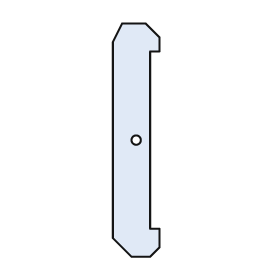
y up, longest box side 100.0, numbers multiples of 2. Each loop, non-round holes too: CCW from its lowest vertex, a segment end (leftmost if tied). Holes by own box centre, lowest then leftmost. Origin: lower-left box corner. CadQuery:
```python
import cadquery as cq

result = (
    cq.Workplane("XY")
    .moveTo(8.0, 0.0)
    .lineTo(16.0, 0.0)
    .lineTo(20.0, 4.0)
    .lineTo(20.0, 12.0)
    .lineTo(16.0, 12.0)
    .lineTo(16.0, 88.0)
    .lineTo(20.0, 88.0)
    .lineTo(20.0, 94.0)
    .lineTo(14.0, 100.0)
    .lineTo(4.0, 100.0)
    .lineTo(0.0, 92.0)
    .lineTo(0.0, 8.0)
    .close()
    .moveTo(10.0, 50.0)
    .circle(2.0)
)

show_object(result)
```